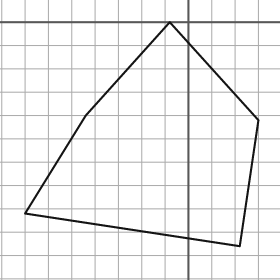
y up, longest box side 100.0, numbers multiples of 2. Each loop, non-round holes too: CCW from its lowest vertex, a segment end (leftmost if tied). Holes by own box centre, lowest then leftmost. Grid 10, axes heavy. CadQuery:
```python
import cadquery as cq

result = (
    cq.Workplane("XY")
    .moveTo(22.0, -96.0)
    .lineTo(30.0, -42.0)
    .lineTo(-8.0, 0.0)
    .lineTo(-44.0, -40.0)
    .lineTo(-70.0, -82.0)
    .close()
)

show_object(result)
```